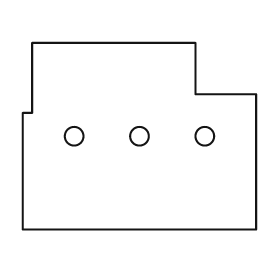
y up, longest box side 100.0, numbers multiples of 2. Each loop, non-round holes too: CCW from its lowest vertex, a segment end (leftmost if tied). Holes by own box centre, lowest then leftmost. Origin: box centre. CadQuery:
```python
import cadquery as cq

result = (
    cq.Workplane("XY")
    .moveTo(-50.0, -40.0)
    .lineTo(50.0, -40.0)
    .lineTo(50.0, 18.0)
    .lineTo(24.0, 18.0)
    .lineTo(24.0, 40.0)
    .lineTo(-46.0, 40.0)
    .lineTo(-46.0, 10.0)
    .lineTo(-50.0, 10.0)
    .close()
    .moveTo(-28.0, 0.0)
    .circle(4.0)
    .moveTo(0.0, 0.0)
    .circle(4.0)
    .moveTo(28.0, 0.0)
    .circle(4.0)
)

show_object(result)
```